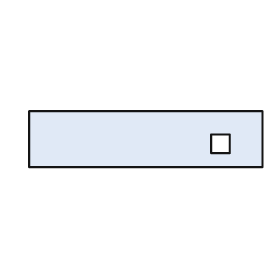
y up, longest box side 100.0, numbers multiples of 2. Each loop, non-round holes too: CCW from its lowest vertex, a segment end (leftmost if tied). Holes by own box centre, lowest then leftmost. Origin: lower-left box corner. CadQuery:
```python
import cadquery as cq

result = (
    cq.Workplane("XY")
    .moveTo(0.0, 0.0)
    .lineTo(100.0, 0.0)
    .lineTo(100.0, 24.0)
    .lineTo(0.0, 24.0)
    .close()
    .moveTo(78.0, 6.0)
    .lineTo(86.0, 6.0)
    .lineTo(86.0, 14.0)
    .lineTo(78.0, 14.0)
    .close()
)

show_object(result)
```